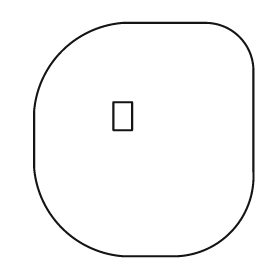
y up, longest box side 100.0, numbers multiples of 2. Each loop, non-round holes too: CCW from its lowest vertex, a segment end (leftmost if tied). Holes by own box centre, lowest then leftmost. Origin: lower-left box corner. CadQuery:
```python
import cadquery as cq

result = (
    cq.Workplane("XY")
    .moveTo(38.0, 0.0)
    .lineTo(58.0, 0.0)
    .threePointArc((84.0, 10.0), (94.0, 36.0))
    .lineTo(94.0, 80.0)
    .threePointArc((88.0, 94.0), (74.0, 100.0))
    .lineTo(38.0, 100.0)
    .threePointArc((12.0, 88.0), (0.0, 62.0))
    .lineTo(0.0, 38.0)
    .threePointArc((12.0, 12.0), (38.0, 0.0))
    .close()
    .moveTo(34.0, 54.0)
    .lineTo(42.0, 54.0)
    .lineTo(42.0, 66.0)
    .lineTo(34.0, 66.0)
    .close()
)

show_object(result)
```